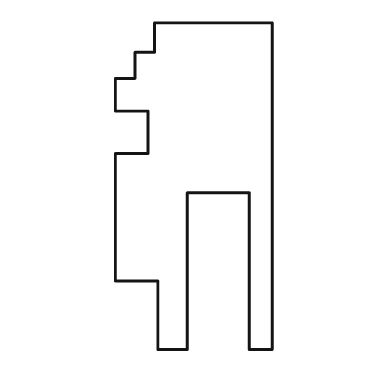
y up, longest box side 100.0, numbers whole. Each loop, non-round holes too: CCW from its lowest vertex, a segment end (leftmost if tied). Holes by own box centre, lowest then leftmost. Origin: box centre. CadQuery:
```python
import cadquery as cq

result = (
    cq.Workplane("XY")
    .moveTo(-11.0, -50.0)
    .lineTo(-2.0, -50.0)
    .lineTo(-2.0, -2.0)
    .lineTo(17.0, -2.0)
    .lineTo(17.0, -50.0)
    .lineTo(24.0, -50.0)
    .lineTo(24.0, 50.0)
    .lineTo(-12.0, 50.0)
    .lineTo(-12.0, 41.0)
    .lineTo(-18.0, 41.0)
    .lineTo(-18.0, 33.0)
    .lineTo(-24.0, 33.0)
    .lineTo(-24.0, 23.0)
    .lineTo(-14.0, 23.0)
    .lineTo(-14.0, 10.0)
    .lineTo(-24.0, 10.0)
    .lineTo(-24.0, -29.0)
    .lineTo(-11.0, -29.0)
    .close()
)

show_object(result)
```